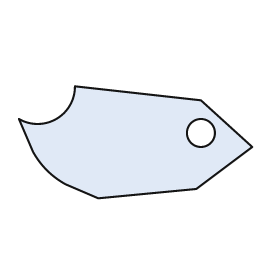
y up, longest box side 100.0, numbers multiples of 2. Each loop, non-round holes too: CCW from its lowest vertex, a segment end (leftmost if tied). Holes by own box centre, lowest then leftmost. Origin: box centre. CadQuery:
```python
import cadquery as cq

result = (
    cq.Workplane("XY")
    .moveTo(-16.0, -24.0)
    .lineTo(26.0, -20.0)
    .lineTo(50.0, -2.0)
    .lineTo(28.0, 18.0)
    .lineTo(-26.0, 24.0)
    .threePointArc((-34.0, 10.0), (-50.0, 10.0))
    .lineTo(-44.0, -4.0)
    .threePointArc((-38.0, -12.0), (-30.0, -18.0))
    .close()
    .moveTo(28.0, 4.0)
    .circle(6.0)
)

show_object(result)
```